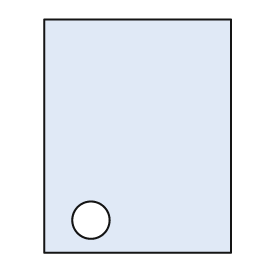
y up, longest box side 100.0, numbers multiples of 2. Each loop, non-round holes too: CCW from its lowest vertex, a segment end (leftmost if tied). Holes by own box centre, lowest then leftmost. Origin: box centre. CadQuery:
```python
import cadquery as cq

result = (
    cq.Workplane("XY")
    .moveTo(-40.0, -50.0)
    .lineTo(40.0, -50.0)
    .lineTo(40.0, 50.0)
    .lineTo(-40.0, 50.0)
    .close()
    .moveTo(-20.0, -36.0)
    .circle(8.0)
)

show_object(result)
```